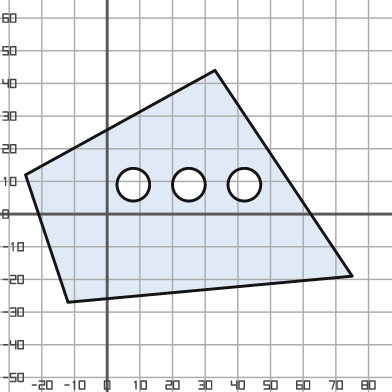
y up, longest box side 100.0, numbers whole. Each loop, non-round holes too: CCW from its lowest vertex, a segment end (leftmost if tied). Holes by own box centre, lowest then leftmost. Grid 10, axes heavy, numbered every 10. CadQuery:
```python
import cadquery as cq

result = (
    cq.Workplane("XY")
    .moveTo(-12.0, -27.0)
    .lineTo(75.0, -19.0)
    .lineTo(33.0, 44.0)
    .lineTo(-25.0, 12.0)
    .close()
    .moveTo(8.0, 9.0)
    .circle(5.0)
    .moveTo(25.0, 9.0)
    .circle(5.0)
    .moveTo(42.0, 9.0)
    .circle(5.0)
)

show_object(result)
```